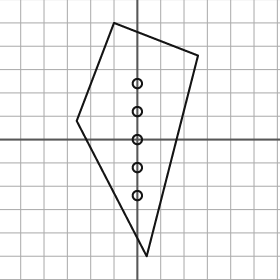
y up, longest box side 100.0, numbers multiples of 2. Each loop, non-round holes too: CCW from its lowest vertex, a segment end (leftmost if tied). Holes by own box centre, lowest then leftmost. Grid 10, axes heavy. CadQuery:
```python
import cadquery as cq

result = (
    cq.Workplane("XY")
    .moveTo(4.0, -50.0)
    .lineTo(26.0, 36.0)
    .lineTo(-10.0, 50.0)
    .lineTo(-26.0, 8.0)
    .close()
    .moveTo(0.0, -24.0)
    .circle(2.0)
    .moveTo(0.0, -12.0)
    .circle(2.0)
    .moveTo(0.0, 0.0)
    .circle(2.0)
    .moveTo(0.0, 12.0)
    .circle(2.0)
    .moveTo(0.0, 24.0)
    .circle(2.0)
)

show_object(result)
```